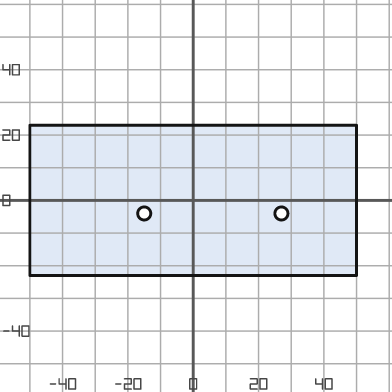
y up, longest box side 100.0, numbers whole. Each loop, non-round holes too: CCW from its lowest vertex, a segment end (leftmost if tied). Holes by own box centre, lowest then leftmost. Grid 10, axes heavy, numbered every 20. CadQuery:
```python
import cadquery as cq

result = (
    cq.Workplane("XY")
    .moveTo(-50.0, -23.0)
    .lineTo(50.0, -23.0)
    .lineTo(50.0, 23.0)
    .lineTo(-50.0, 23.0)
    .close()
    .moveTo(-15.0, -4.0)
    .circle(2.0)
    .moveTo(27.0, -4.0)
    .circle(2.0)
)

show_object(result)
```